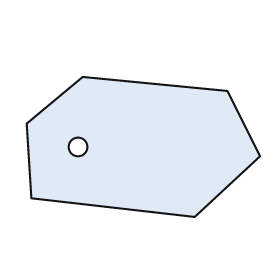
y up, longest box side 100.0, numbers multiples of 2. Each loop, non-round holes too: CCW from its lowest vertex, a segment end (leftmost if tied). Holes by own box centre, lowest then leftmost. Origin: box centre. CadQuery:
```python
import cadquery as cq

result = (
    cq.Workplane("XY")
    .moveTo(22.0, -30.0)
    .lineTo(50.0, -4.0)
    .lineTo(36.0, 24.0)
    .lineTo(-26.0, 30.0)
    .lineTo(-50.0, 10.0)
    .lineTo(-48.0, -22.0)
    .close()
    .moveTo(-28.0, 0.0)
    .circle(4.0)
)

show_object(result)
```